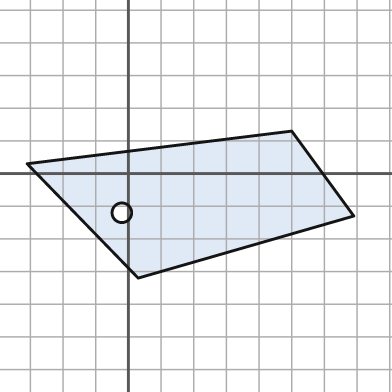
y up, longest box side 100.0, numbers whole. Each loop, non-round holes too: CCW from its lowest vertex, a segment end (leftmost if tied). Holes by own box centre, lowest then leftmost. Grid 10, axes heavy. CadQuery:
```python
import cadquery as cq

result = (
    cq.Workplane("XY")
    .moveTo(3.0, -32.0)
    .lineTo(69.0, -13.0)
    .lineTo(50.0, 13.0)
    .lineTo(-31.0, 3.0)
    .close()
    .moveTo(-2.0, -12.0)
    .circle(3.0)
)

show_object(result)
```